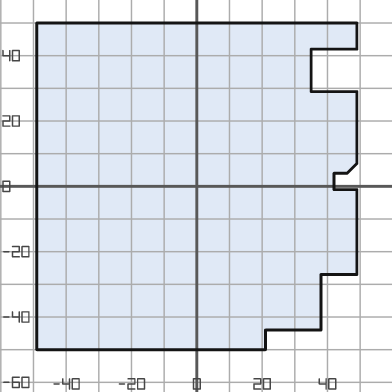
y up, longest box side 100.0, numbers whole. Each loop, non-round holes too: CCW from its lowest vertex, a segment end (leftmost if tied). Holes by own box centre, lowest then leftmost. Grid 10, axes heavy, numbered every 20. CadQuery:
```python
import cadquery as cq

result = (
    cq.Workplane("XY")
    .moveTo(-49.0, -50.0)
    .lineTo(21.0, -50.0)
    .lineTo(21.0, -44.0)
    .lineTo(38.0, -44.0)
    .lineTo(38.0, -27.0)
    .lineTo(49.0, -27.0)
    .lineTo(49.0, -1.0)
    .lineTo(42.0, -1.0)
    .lineTo(42.0, 4.0)
    .lineTo(46.0, 4.0)
    .lineTo(49.0, 7.0)
    .lineTo(49.0, 29.0)
    .lineTo(35.0, 29.0)
    .lineTo(35.0, 42.0)
    .lineTo(49.0, 42.0)
    .lineTo(49.0, 50.0)
    .lineTo(-49.0, 50.0)
    .close()
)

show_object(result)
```